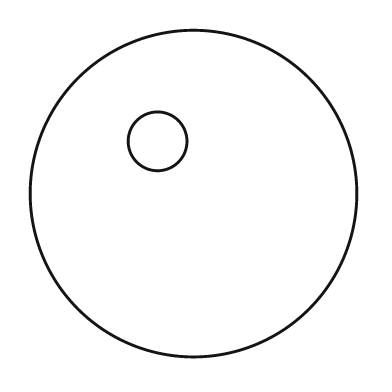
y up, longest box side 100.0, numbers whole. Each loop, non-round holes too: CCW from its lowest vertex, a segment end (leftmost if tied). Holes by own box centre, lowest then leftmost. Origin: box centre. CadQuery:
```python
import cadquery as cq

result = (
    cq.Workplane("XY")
    .moveTo(0.0, 0.0)
    .circle(50.0)
    .moveTo(-11.0, 16.0)
    .circle(9.0)
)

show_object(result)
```